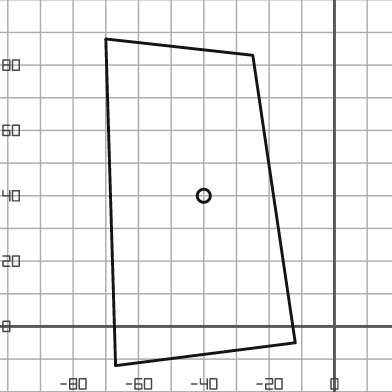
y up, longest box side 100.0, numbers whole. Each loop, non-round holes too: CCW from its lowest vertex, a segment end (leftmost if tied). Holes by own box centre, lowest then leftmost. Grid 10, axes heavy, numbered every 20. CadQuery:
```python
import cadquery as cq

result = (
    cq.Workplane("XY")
    .moveTo(-67.0, -12.0)
    .lineTo(-12.0, -5.0)
    .lineTo(-25.0, 83.0)
    .lineTo(-70.0, 88.0)
    .close()
    .moveTo(-40.0, 40.0)
    .circle(2.0)
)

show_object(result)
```